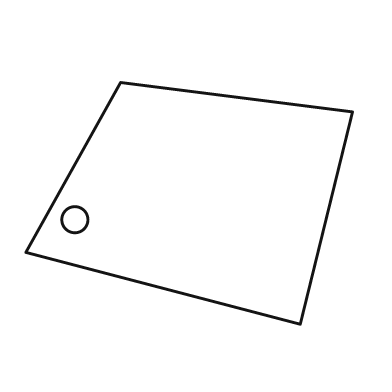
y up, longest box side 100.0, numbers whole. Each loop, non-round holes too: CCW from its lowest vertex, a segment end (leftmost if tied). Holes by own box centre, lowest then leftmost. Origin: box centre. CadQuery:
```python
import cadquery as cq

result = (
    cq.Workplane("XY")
    .moveTo(34.0, -37.0)
    .lineTo(50.0, 28.0)
    .lineTo(-21.0, 37.0)
    .lineTo(-50.0, -15.0)
    .close()
    .moveTo(-35.0, -5.0)
    .circle(4.0)
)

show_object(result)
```